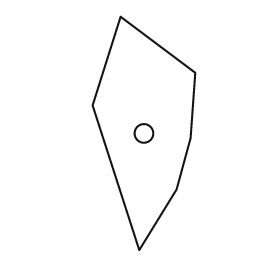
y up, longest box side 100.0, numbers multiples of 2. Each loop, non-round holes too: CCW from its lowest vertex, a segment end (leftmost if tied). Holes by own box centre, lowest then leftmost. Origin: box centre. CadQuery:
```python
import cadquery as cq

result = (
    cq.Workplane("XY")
    .moveTo(-2.0, -50.0)
    .lineTo(14.0, -24.0)
    .lineTo(20.0, -2.0)
    .lineTo(22.0, 26.0)
    .lineTo(-10.0, 50.0)
    .lineTo(-22.0, 12.0)
    .close()
    .moveTo(0.0, 0.0)
    .circle(4.0)
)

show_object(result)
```